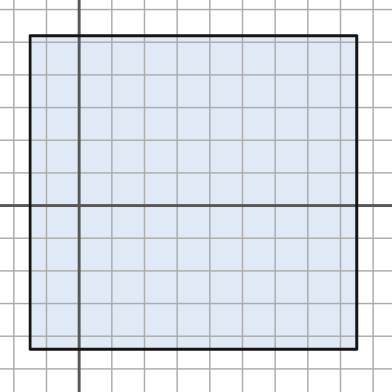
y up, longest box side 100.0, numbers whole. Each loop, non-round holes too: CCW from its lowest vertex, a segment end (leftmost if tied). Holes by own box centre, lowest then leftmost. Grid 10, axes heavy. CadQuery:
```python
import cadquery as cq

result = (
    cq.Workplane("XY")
    .moveTo(-15.0, -44.0)
    .lineTo(85.0, -44.0)
    .lineTo(85.0, 52.0)
    .lineTo(-15.0, 52.0)
    .close()
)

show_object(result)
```